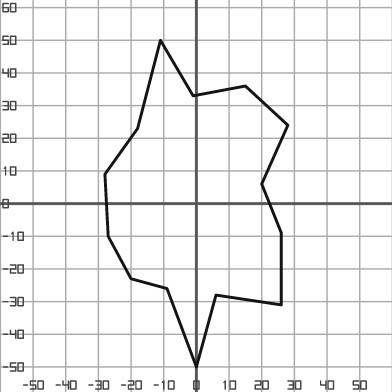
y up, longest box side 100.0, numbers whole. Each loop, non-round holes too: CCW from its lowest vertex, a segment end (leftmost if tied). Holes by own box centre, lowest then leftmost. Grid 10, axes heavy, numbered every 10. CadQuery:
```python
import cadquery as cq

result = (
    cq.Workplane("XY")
    .moveTo(0.0, -50.0)
    .lineTo(6.0, -28.0)
    .lineTo(26.0, -31.0)
    .lineTo(26.0, -9.0)
    .lineTo(20.0, 6.0)
    .lineTo(28.0, 24.0)
    .lineTo(15.0, 36.0)
    .lineTo(-1.0, 33.0)
    .lineTo(-11.0, 50.0)
    .lineTo(-18.0, 23.0)
    .lineTo(-28.0, 9.0)
    .lineTo(-27.0, -10.0)
    .lineTo(-20.0, -23.0)
    .lineTo(-9.0, -26.0)
    .close()
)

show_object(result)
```